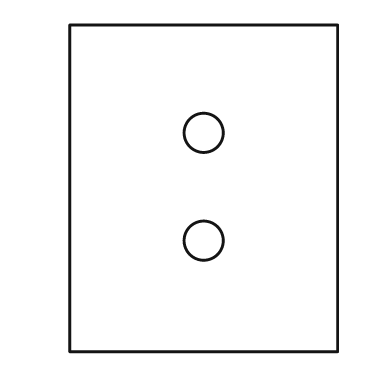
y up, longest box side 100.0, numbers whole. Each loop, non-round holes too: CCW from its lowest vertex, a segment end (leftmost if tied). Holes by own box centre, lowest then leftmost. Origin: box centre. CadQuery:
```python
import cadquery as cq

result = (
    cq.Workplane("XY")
    .moveTo(-41.0, -50.0)
    .lineTo(41.0, -50.0)
    .lineTo(41.0, 50.0)
    .lineTo(-41.0, 50.0)
    .close()
    .moveTo(0.0, -16.0)
    .circle(6.0)
    .moveTo(0.0, 17.0)
    .circle(6.0)
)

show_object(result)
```